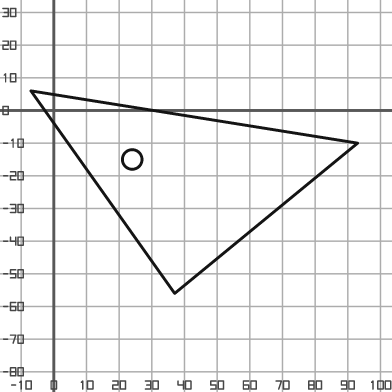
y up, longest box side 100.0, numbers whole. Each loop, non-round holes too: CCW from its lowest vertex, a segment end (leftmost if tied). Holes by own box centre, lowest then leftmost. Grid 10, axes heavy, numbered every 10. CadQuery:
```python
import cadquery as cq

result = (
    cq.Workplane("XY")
    .moveTo(37.0, -56.0)
    .lineTo(93.0, -10.0)
    .lineTo(-7.0, 6.0)
    .close()
    .moveTo(24.0, -15.0)
    .circle(3.0)
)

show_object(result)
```